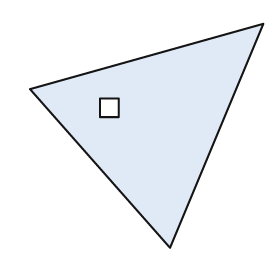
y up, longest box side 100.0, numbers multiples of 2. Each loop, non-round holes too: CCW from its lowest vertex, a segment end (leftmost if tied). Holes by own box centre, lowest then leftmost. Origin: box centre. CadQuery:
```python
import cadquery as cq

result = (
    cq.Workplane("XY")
    .moveTo(10.0, -48.0)
    .lineTo(50.0, 48.0)
    .lineTo(-50.0, 20.0)
    .close()
    .moveTo(-20.0, 8.0)
    .lineTo(-12.0, 8.0)
    .lineTo(-12.0, 16.0)
    .lineTo(-20.0, 16.0)
    .close()
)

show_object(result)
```